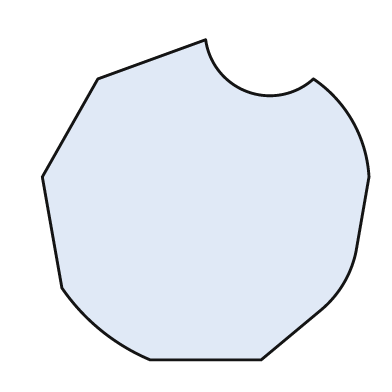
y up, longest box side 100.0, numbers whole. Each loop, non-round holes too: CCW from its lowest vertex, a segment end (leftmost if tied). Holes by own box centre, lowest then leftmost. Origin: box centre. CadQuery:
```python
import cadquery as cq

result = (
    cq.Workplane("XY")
    .moveTo(-17.0, -49.0)
    .lineTo(17.0, -49.0)
    .lineTo(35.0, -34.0)
    .threePointArc((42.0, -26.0), (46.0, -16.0))
    .lineTo(50.0, 7.0)
    .threePointArc((45.0, 24.0), (33.0, 37.0))
    .threePointArc((13.0, 33.0), (0.0, 49.0))
    .lineTo(-33.0, 37.0)
    .lineTo(-50.0, 7.0)
    .lineTo(-44.0, -27.0)
    .threePointArc((-32.0, -40.0), (-17.0, -49.0))
    .close()
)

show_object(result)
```